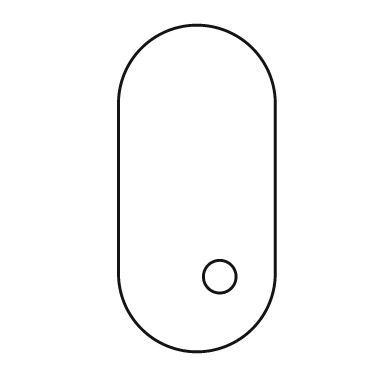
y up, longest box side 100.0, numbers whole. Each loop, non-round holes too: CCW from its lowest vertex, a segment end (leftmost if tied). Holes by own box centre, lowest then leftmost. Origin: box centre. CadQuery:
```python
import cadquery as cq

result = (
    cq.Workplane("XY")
    .moveTo(-24.0, -26.0)
    .threePointArc((0.0, -50.0), (24.0, -26.0))
    .lineTo(24.0, 26.0)
    .threePointArc((0.0, 50.0), (-24.0, 26.0))
    .close()
    .moveTo(7.0, -27.0)
    .circle(5.0)
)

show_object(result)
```